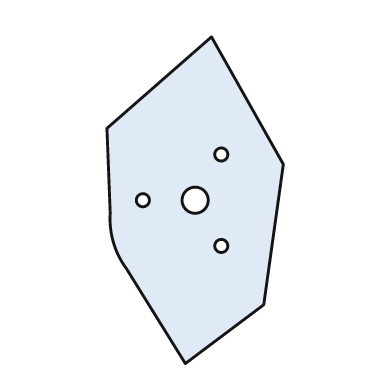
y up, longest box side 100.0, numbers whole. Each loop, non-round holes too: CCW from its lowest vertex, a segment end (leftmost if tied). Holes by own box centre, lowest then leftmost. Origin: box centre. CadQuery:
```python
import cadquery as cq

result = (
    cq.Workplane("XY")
    .moveTo(-3.0, -50.0)
    .lineTo(21.0, -32.0)
    .lineTo(27.0, 11.0)
    .lineTo(5.0, 50.0)
    .lineTo(-27.0, 22.0)
    .lineTo(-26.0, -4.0)
    .threePointArc((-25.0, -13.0), (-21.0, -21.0))
    .close()
    .moveTo(8.0, -14.0)
    .circle(2.0)
    .moveTo(-16.0, 0.0)
    .circle(2.0)
    .moveTo(0.0, 0.0)
    .circle(4.0)
    .moveTo(8.0, 14.0)
    .circle(2.0)
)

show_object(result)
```